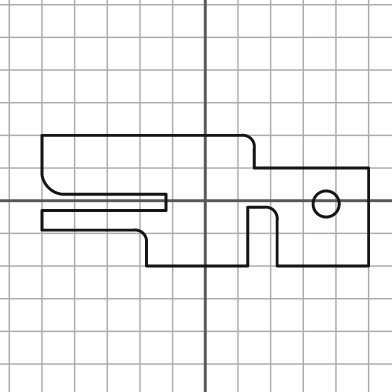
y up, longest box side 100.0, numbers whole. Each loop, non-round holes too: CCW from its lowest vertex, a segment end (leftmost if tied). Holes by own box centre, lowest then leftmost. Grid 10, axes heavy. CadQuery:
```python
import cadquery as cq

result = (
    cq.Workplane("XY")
    .moveTo(-18.0, -20.0)
    .lineTo(13.0, -20.0)
    .lineTo(13.0, -2.0)
    .lineTo(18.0, -2.0)
    .threePointArc((21.0, -3.0), (22.0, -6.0))
    .lineTo(22.0, -20.0)
    .lineTo(50.0, -20.0)
    .lineTo(50.0, 10.0)
    .lineTo(15.0, 10.0)
    .lineTo(15.0, 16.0)
    .threePointArc((14.0, 19.0), (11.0, 20.0))
    .lineTo(-50.0, 20.0)
    .lineTo(-50.0, 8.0)
    .threePointArc((-48.0, 4.0), (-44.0, 2.0))
    .lineTo(-12.0, 2.0)
    .lineTo(-12.0, -3.0)
    .lineTo(-50.0, -3.0)
    .lineTo(-50.0, -9.0)
    .lineTo(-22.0, -9.0)
    .threePointArc((-19.0, -10.0), (-18.0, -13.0))
    .close()
    .moveTo(37.0, -1.0)
    .circle(4.0)
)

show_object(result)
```